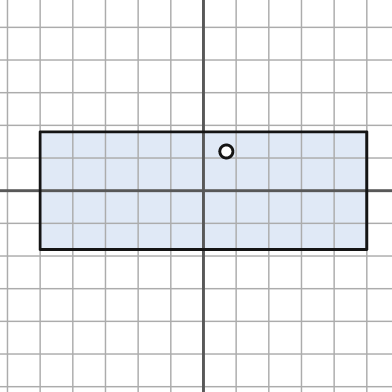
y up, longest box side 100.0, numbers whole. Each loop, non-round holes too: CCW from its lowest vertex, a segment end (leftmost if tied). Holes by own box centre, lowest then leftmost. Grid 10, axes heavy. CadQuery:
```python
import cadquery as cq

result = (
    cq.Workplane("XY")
    .moveTo(-50.0, -18.0)
    .lineTo(50.0, -18.0)
    .lineTo(50.0, 18.0)
    .lineTo(-50.0, 18.0)
    .close()
    .moveTo(7.0, 12.0)
    .circle(2.0)
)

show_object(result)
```